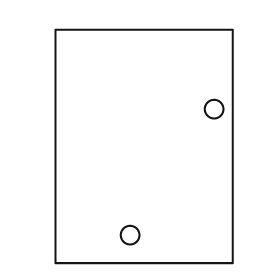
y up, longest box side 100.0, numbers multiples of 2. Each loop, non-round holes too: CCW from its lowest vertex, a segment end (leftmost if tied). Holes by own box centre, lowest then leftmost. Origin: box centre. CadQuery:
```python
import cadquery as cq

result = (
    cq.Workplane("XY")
    .moveTo(-38.0, -50.0)
    .lineTo(38.0, -50.0)
    .lineTo(38.0, 50.0)
    .lineTo(-38.0, 50.0)
    .close()
    .moveTo(-6.0, -38.0)
    .circle(4.0)
    .moveTo(30.0, 16.0)
    .circle(4.0)
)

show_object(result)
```